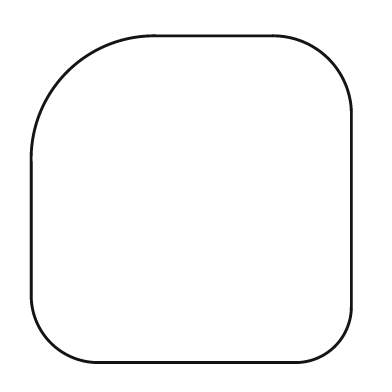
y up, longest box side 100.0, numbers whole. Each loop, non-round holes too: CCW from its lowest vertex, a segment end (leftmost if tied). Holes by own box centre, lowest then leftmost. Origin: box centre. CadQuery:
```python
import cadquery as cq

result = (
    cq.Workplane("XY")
    .moveTo(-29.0, -50.0)
    .lineTo(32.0, -50.0)
    .threePointArc((44.0, -45.0), (49.0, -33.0))
    .lineTo(49.0, 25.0)
    .threePointArc((42.0, 43.0), (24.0, 50.0))
    .lineTo(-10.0, 50.0)
    .threePointArc((-38.0, 39.0), (-49.0, 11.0))
    .lineTo(-49.0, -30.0)
    .threePointArc((-43.0, -44.0), (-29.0, -50.0))
    .close()
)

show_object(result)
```